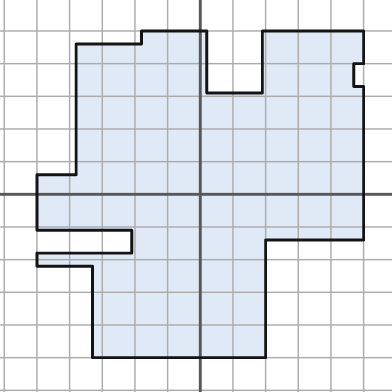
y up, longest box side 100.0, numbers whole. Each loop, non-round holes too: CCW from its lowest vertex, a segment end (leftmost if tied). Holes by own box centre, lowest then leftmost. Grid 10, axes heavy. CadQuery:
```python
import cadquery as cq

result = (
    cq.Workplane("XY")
    .moveTo(-33.0, -50.0)
    .lineTo(20.0, -50.0)
    .lineTo(20.0, -14.0)
    .lineTo(50.0, -14.0)
    .lineTo(50.0, 33.0)
    .lineTo(47.0, 33.0)
    .lineTo(47.0, 40.0)
    .lineTo(50.0, 40.0)
    .lineTo(50.0, 50.0)
    .lineTo(19.0, 50.0)
    .lineTo(19.0, 31.0)
    .lineTo(2.0, 31.0)
    .lineTo(2.0, 50.0)
    .lineTo(-18.0, 50.0)
    .lineTo(-18.0, 46.0)
    .lineTo(-38.0, 46.0)
    .lineTo(-38.0, 6.0)
    .lineTo(-50.0, 6.0)
    .lineTo(-50.0, -11.0)
    .lineTo(-21.0, -11.0)
    .lineTo(-21.0, -18.0)
    .lineTo(-50.0, -18.0)
    .lineTo(-50.0, -22.0)
    .lineTo(-33.0, -22.0)
    .close()
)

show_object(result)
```